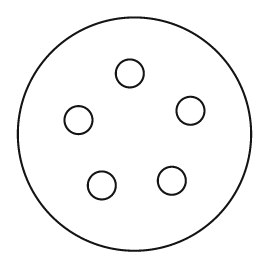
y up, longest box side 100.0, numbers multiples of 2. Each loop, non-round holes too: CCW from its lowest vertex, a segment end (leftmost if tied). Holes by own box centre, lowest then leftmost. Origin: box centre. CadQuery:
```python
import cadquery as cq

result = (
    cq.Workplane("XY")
    .moveTo(0.0, 0.0)
    .circle(50.0)
    .moveTo(-14.0, -22.0)
    .circle(6.0)
    .moveTo(16.0, -20.0)
    .circle(6.0)
    .moveTo(-24.0, 6.0)
    .circle(6.0)
    .moveTo(24.0, 10.0)
    .circle(6.0)
    .moveTo(-2.0, 26.0)
    .circle(6.0)
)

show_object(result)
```